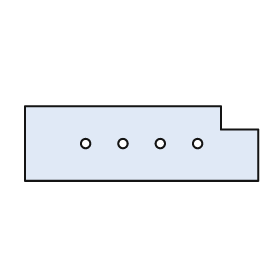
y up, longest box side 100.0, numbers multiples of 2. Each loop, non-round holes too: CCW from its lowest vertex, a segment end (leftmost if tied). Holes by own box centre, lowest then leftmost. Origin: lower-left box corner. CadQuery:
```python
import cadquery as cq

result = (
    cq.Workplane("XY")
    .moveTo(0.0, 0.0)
    .lineTo(100.0, 0.0)
    .lineTo(100.0, 22.0)
    .lineTo(84.0, 22.0)
    .lineTo(84.0, 32.0)
    .lineTo(0.0, 32.0)
    .close()
    .moveTo(26.0, 16.0)
    .circle(2.0)
    .moveTo(42.0, 16.0)
    .circle(2.0)
    .moveTo(58.0, 16.0)
    .circle(2.0)
    .moveTo(74.0, 16.0)
    .circle(2.0)
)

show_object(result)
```